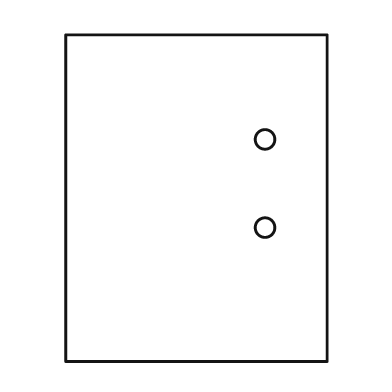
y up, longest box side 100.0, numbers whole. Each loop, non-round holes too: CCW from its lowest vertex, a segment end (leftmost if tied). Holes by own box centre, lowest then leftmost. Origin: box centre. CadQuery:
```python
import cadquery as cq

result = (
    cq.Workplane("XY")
    .moveTo(-40.0, -50.0)
    .lineTo(40.0, -50.0)
    .lineTo(40.0, 50.0)
    .lineTo(-40.0, 50.0)
    .close()
    .moveTo(21.0, -9.0)
    .circle(3.0)
    .moveTo(21.0, 18.0)
    .circle(3.0)
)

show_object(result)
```